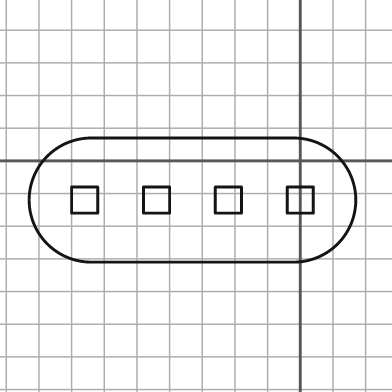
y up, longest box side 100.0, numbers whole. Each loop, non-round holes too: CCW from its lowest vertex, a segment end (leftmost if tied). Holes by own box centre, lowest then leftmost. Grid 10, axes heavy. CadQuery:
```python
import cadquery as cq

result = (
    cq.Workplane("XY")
    .moveTo(-64.0, -31.0)
    .lineTo(-2.0, -31.0)
    .threePointArc((17.0, -12.0), (-2.0, 7.0))
    .lineTo(-64.0, 7.0)
    .threePointArc((-83.0, -12.0), (-64.0, -31.0))
    .close()
    .moveTo(-70.0, -16.0)
    .lineTo(-62.0, -16.0)
    .lineTo(-62.0, -8.0)
    .lineTo(-70.0, -8.0)
    .close()
    .moveTo(-48.0, -16.0)
    .lineTo(-40.0, -16.0)
    .lineTo(-40.0, -8.0)
    .lineTo(-48.0, -8.0)
    .close()
    .moveTo(-26.0, -16.0)
    .lineTo(-18.0, -16.0)
    .lineTo(-18.0, -8.0)
    .lineTo(-26.0, -8.0)
    .close()
    .moveTo(-4.0, -16.0)
    .lineTo(4.0, -16.0)
    .lineTo(4.0, -8.0)
    .lineTo(-4.0, -8.0)
    .close()
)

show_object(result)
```